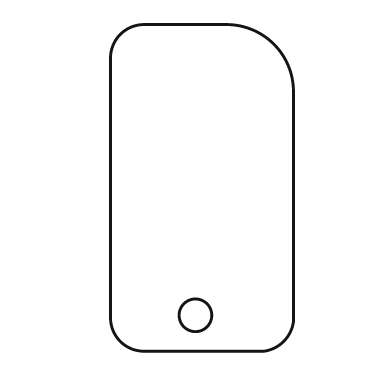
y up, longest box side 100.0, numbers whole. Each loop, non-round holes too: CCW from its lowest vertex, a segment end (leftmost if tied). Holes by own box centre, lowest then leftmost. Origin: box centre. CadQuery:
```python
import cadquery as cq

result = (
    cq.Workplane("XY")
    .moveTo(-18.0, -50.0)
    .lineTo(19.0, -50.0)
    .threePointArc((25.0, -47.0), (28.0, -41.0))
    .lineTo(28.0, 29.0)
    .threePointArc((22.0, 44.0), (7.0, 50.0))
    .lineTo(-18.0, 50.0)
    .threePointArc((-25.0, 47.0), (-28.0, 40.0))
    .lineTo(-28.0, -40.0)
    .threePointArc((-25.0, -47.0), (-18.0, -50.0))
    .close()
    .moveTo(-2.0, -39.0)
    .circle(5.0)
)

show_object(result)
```